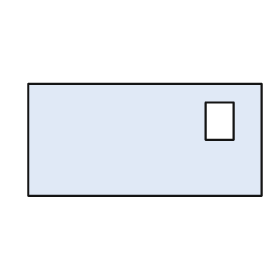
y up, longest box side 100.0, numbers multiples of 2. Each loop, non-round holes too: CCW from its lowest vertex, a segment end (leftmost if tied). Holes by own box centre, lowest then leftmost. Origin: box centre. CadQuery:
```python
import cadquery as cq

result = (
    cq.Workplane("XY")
    .moveTo(-50.0, -24.0)
    .lineTo(50.0, -24.0)
    .lineTo(50.0, 24.0)
    .lineTo(-50.0, 24.0)
    .close()
    .moveTo(26.0, 0.0)
    .lineTo(38.0, 0.0)
    .lineTo(38.0, 16.0)
    .lineTo(26.0, 16.0)
    .close()
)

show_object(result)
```